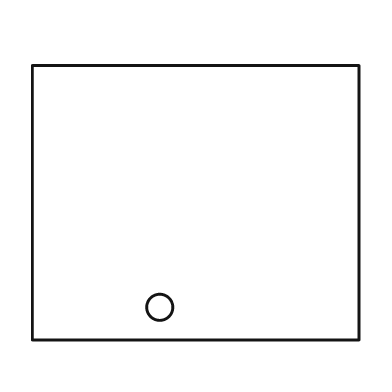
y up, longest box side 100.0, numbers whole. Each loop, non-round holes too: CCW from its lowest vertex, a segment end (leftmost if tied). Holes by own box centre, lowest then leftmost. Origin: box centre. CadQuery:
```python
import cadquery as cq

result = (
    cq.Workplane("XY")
    .moveTo(-50.0, -42.0)
    .lineTo(50.0, -42.0)
    .lineTo(50.0, 42.0)
    .lineTo(-50.0, 42.0)
    .close()
    .moveTo(-11.0, -32.0)
    .circle(4.0)
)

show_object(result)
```